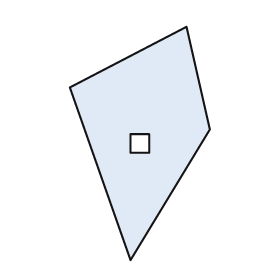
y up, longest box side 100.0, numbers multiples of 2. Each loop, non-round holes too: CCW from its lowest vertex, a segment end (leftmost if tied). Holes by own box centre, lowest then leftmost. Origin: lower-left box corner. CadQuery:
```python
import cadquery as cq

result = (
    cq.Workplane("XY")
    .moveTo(26.0, 0.0)
    .lineTo(60.0, 56.0)
    .lineTo(50.0, 100.0)
    .lineTo(0.0, 74.0)
    .close()
    .moveTo(26.0, 46.0)
    .lineTo(34.0, 46.0)
    .lineTo(34.0, 54.0)
    .lineTo(26.0, 54.0)
    .close()
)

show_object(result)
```